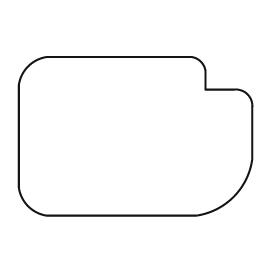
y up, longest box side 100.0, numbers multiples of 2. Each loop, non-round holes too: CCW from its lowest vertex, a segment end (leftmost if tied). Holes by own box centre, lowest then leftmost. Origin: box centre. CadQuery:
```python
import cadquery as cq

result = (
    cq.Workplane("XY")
    .moveTo(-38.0, -34.0)
    .lineTo(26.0, -34.0)
    .threePointArc((42.0, -26.0), (50.0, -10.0))
    .lineTo(50.0, 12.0)
    .threePointArc((48.0, 18.0), (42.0, 20.0))
    .lineTo(30.0, 20.0)
    .lineTo(30.0, 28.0)
    .threePointArc((28.0, 32.0), (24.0, 34.0))
    .lineTo(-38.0, 34.0)
    .threePointArc((-46.0, 30.0), (-50.0, 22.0))
    .lineTo(-50.0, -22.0)
    .threePointArc((-46.0, -30.0), (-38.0, -34.0))
    .close()
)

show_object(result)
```